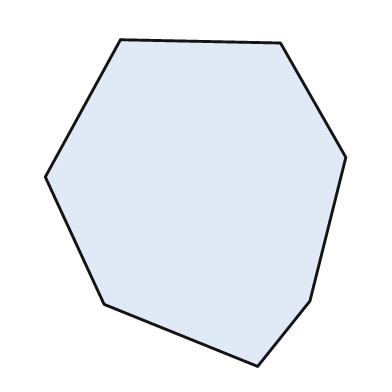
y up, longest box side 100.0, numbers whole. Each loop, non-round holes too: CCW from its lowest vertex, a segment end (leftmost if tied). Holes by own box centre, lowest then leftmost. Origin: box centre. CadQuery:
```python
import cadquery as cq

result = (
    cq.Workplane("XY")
    .moveTo(19.0, -50.0)
    .lineTo(35.0, -30.0)
    .lineTo(46.0, 14.0)
    .lineTo(26.0, 49.0)
    .lineTo(-23.0, 50.0)
    .lineTo(-46.0, 8.0)
    .lineTo(-28.0, -31.0)
    .close()
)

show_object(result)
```